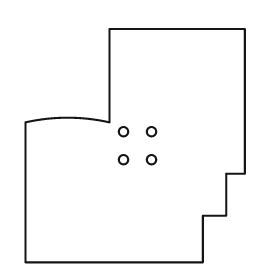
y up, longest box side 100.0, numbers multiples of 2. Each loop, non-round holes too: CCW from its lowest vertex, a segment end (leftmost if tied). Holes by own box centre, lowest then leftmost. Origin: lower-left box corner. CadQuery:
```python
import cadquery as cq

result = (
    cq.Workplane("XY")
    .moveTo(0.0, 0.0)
    .lineTo(76.0, 0.0)
    .lineTo(76.0, 20.0)
    .lineTo(86.0, 20.0)
    .lineTo(86.0, 38.0)
    .lineTo(94.0, 38.0)
    .lineTo(94.0, 100.0)
    .lineTo(36.0, 100.0)
    .lineTo(36.0, 60.0)
    .threePointArc((18.0, 62.0), (0.0, 60.0))
    .close()
    .moveTo(42.0, 44.0)
    .circle(2.0)
    .moveTo(54.0, 44.0)
    .circle(2.0)
    .moveTo(42.0, 56.0)
    .circle(2.0)
    .moveTo(54.0, 56.0)
    .circle(2.0)
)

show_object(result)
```